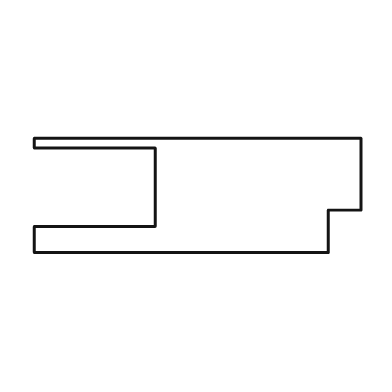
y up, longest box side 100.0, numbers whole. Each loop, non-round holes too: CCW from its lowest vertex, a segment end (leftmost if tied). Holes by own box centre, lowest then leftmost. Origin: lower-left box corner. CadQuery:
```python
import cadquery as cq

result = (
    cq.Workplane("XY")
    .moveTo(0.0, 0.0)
    .lineTo(90.0, 0.0)
    .lineTo(90.0, 13.0)
    .lineTo(100.0, 13.0)
    .lineTo(100.0, 35.0)
    .lineTo(0.0, 35.0)
    .lineTo(0.0, 32.0)
    .lineTo(37.0, 32.0)
    .lineTo(37.0, 8.0)
    .lineTo(0.0, 8.0)
    .close()
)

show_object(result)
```